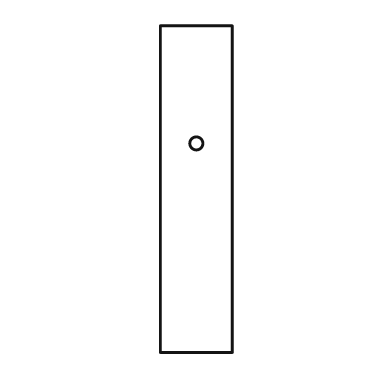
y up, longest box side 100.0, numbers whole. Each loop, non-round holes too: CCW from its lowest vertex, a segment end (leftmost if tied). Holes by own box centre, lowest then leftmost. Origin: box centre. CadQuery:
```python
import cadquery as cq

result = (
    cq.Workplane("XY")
    .moveTo(-11.0, -50.0)
    .lineTo(11.0, -50.0)
    .lineTo(11.0, 50.0)
    .lineTo(-11.0, 50.0)
    .close()
    .moveTo(0.0, 14.0)
    .circle(2.0)
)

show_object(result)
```